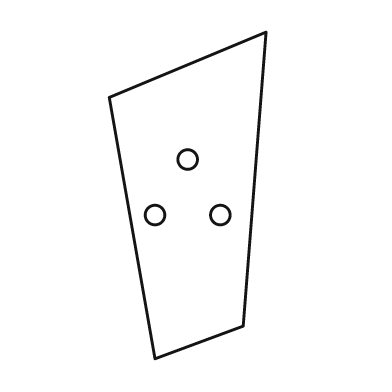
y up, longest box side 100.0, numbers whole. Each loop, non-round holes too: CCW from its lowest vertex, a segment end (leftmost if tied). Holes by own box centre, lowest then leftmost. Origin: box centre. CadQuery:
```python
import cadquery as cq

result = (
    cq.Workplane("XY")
    .moveTo(-10.0, -50.0)
    .lineTo(17.0, -40.0)
    .lineTo(24.0, 50.0)
    .lineTo(-24.0, 30.0)
    .close()
    .moveTo(-10.0, -6.0)
    .circle(3.0)
    .moveTo(10.0, -6.0)
    .circle(3.0)
    .moveTo(0.0, 11.0)
    .circle(3.0)
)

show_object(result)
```